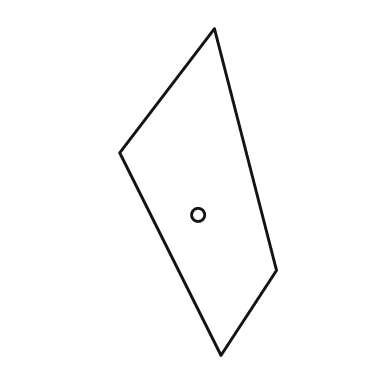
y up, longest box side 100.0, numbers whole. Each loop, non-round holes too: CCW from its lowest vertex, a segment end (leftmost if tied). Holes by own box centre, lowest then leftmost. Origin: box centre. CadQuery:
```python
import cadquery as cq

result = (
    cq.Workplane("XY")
    .moveTo(7.0, -50.0)
    .lineTo(24.0, -24.0)
    .lineTo(5.0, 50.0)
    .lineTo(-24.0, 12.0)
    .close()
    .moveTo(0.0, -7.0)
    .circle(2.0)
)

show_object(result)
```